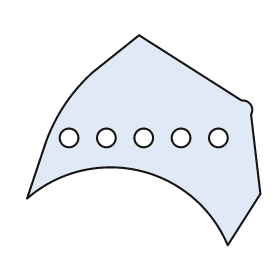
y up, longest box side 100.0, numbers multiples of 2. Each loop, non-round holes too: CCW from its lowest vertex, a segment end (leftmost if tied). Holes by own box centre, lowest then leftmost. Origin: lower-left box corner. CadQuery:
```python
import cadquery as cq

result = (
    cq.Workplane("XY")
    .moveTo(86.0, 0.0)
    .lineTo(100.0, 22.0)
    .lineTo(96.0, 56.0)
    .threePointArc((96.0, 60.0), (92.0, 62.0))
    .lineTo(48.0, 90.0)
    .lineTo(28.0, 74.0)
    .threePointArc((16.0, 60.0), (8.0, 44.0))
    .lineTo(0.0, 20.0)
    .threePointArc((48.0, 32.0), (86.0, 0.0))
    .close()
    .moveTo(18.0, 46.0)
    .circle(4.0)
    .moveTo(34.0, 46.0)
    .circle(4.0)
    .moveTo(50.0, 46.0)
    .circle(4.0)
    .moveTo(66.0, 46.0)
    .circle(4.0)
    .moveTo(82.0, 46.0)
    .circle(4.0)
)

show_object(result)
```